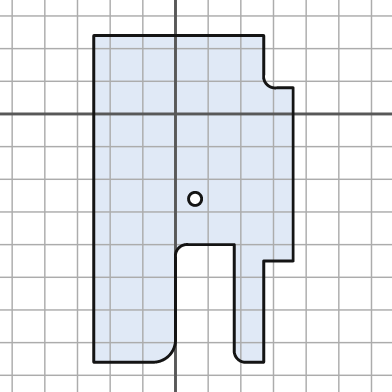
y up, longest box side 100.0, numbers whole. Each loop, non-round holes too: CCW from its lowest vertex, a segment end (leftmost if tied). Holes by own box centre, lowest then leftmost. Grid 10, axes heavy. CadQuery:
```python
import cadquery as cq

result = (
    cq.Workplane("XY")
    .moveTo(-25.0, -76.0)
    .lineTo(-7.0, -76.0)
    .threePointArc((-2.0, -74.0), (0.0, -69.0))
    .lineTo(0.0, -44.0)
    .threePointArc((1.0, -41.0), (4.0, -40.0))
    .lineTo(18.0, -40.0)
    .lineTo(18.0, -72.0)
    .threePointArc((19.0, -75.0), (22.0, -76.0))
    .lineTo(27.0, -76.0)
    .lineTo(27.0, -45.0)
    .lineTo(36.0, -45.0)
    .lineTo(36.0, 8.0)
    .lineTo(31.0, 8.0)
    .threePointArc((28.0, 9.0), (27.0, 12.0))
    .lineTo(27.0, 24.0)
    .lineTo(-25.0, 24.0)
    .close()
    .moveTo(6.0, -26.0)
    .circle(2.0)
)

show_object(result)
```